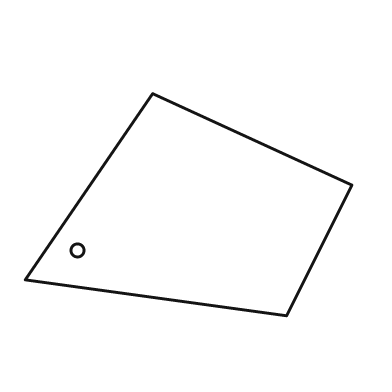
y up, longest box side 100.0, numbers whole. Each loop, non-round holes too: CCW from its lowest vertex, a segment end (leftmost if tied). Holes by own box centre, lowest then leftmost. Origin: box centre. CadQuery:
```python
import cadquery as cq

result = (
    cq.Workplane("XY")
    .moveTo(30.0, -34.0)
    .lineTo(50.0, 6.0)
    .lineTo(-11.0, 34.0)
    .lineTo(-50.0, -23.0)
    .close()
    .moveTo(-34.0, -14.0)
    .circle(2.0)
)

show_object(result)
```